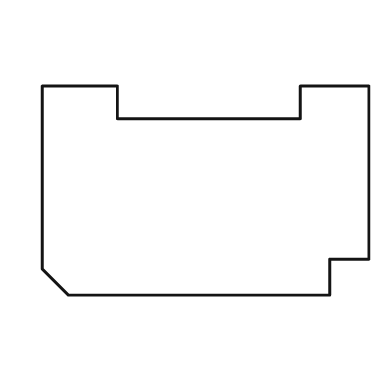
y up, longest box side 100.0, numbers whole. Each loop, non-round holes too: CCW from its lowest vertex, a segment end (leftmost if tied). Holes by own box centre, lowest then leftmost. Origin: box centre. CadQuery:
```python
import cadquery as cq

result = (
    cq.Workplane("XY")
    .moveTo(-42.0, -32.0)
    .lineTo(38.0, -32.0)
    .lineTo(38.0, -21.0)
    .lineTo(50.0, -21.0)
    .lineTo(50.0, 32.0)
    .lineTo(29.0, 32.0)
    .lineTo(29.0, 22.0)
    .lineTo(-27.0, 22.0)
    .lineTo(-27.0, 32.0)
    .lineTo(-50.0, 32.0)
    .lineTo(-50.0, -24.0)
    .close()
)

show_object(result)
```